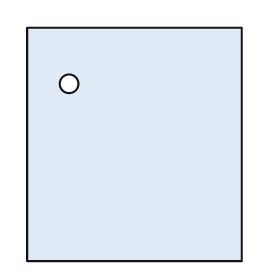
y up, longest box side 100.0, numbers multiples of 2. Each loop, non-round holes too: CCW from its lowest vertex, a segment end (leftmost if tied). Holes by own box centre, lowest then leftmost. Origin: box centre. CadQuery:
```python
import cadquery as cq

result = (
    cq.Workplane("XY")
    .moveTo(-46.0, -50.0)
    .lineTo(46.0, -50.0)
    .lineTo(46.0, 50.0)
    .lineTo(-46.0, 50.0)
    .close()
    .moveTo(-28.0, 26.0)
    .circle(4.0)
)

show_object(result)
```